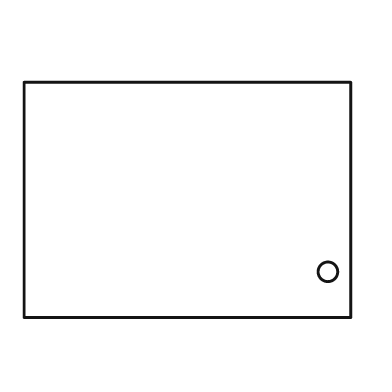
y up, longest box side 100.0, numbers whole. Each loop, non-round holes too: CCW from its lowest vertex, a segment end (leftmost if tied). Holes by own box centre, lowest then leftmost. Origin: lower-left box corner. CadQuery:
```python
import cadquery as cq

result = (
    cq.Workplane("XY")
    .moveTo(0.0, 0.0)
    .lineTo(100.0, 0.0)
    .lineTo(100.0, 72.0)
    .lineTo(0.0, 72.0)
    .close()
    .moveTo(93.0, 14.0)
    .circle(3.0)
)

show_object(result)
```